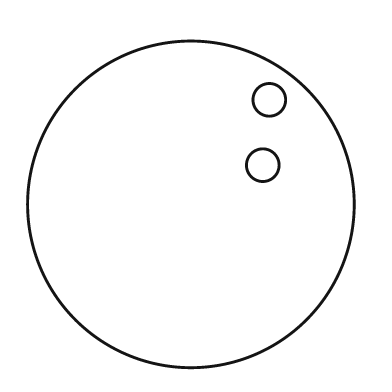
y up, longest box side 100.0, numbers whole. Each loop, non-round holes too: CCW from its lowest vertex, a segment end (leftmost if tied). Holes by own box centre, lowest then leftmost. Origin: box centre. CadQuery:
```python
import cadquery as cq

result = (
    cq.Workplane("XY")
    .moveTo(0.0, 0.0)
    .circle(50.0)
    .moveTo(22.0, 12.0)
    .circle(5.0)
    .moveTo(24.0, 32.0)
    .circle(5.0)
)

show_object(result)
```